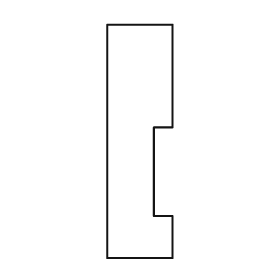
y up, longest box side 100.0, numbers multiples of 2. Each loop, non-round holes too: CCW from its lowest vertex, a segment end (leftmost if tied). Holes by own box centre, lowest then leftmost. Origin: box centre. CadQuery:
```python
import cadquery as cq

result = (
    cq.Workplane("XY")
    .moveTo(-14.0, -50.0)
    .lineTo(14.0, -50.0)
    .lineTo(14.0, -32.0)
    .lineTo(6.0, -32.0)
    .lineTo(6.0, 6.0)
    .lineTo(14.0, 6.0)
    .lineTo(14.0, 50.0)
    .lineTo(-14.0, 50.0)
    .close()
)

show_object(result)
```